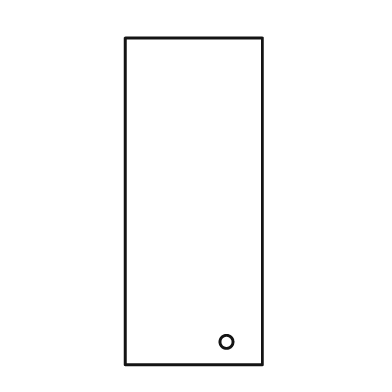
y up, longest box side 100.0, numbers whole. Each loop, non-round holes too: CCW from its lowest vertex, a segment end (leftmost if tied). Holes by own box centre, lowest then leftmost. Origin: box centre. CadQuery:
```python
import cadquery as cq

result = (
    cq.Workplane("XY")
    .moveTo(-21.0, -50.0)
    .lineTo(21.0, -50.0)
    .lineTo(21.0, 50.0)
    .lineTo(-21.0, 50.0)
    .close()
    .moveTo(10.0, -43.0)
    .circle(2.0)
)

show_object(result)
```